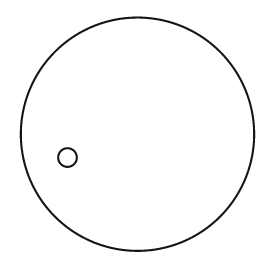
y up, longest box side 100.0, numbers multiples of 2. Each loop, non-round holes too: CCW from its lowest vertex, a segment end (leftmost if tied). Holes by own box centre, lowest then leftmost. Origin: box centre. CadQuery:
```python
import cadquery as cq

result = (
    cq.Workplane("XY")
    .moveTo(0.0, 0.0)
    .circle(50.0)
    .moveTo(-30.0, -10.0)
    .circle(4.0)
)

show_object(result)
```